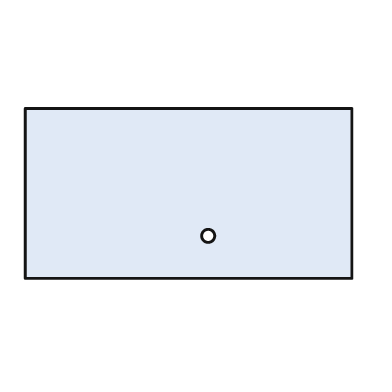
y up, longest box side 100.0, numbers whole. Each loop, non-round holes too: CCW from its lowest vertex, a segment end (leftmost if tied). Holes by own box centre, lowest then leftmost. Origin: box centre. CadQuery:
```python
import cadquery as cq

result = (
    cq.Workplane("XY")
    .moveTo(-50.0, -26.0)
    .lineTo(50.0, -26.0)
    .lineTo(50.0, 26.0)
    .lineTo(-50.0, 26.0)
    .close()
    .moveTo(6.0, -13.0)
    .circle(2.0)
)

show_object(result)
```